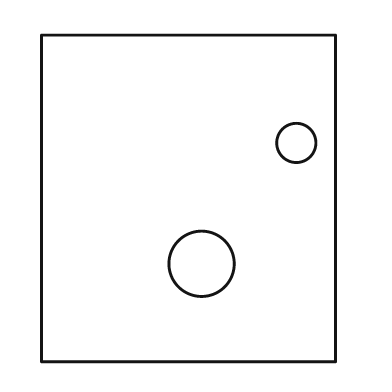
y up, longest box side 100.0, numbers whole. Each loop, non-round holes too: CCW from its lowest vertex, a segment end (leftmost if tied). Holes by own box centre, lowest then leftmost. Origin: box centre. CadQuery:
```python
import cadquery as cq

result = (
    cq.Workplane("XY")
    .moveTo(-45.0, -50.0)
    .lineTo(45.0, -50.0)
    .lineTo(45.0, 50.0)
    .lineTo(-45.0, 50.0)
    .close()
    .moveTo(4.0, -20.0)
    .circle(10.0)
    .moveTo(33.0, 17.0)
    .circle(6.0)
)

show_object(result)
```